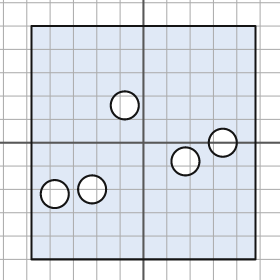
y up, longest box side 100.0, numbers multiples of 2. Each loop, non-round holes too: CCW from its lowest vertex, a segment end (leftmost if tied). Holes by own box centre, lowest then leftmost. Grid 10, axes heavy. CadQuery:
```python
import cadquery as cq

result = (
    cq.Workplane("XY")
    .moveTo(-48.0, -50.0)
    .lineTo(48.0, -50.0)
    .lineTo(48.0, 50.0)
    .lineTo(-48.0, 50.0)
    .close()
    .moveTo(-38.0, -22.0)
    .circle(6.0)
    .moveTo(-22.0, -20.0)
    .circle(6.0)
    .moveTo(18.0, -8.0)
    .circle(6.0)
    .moveTo(34.0, 0.0)
    .circle(6.0)
    .moveTo(-8.0, 16.0)
    .circle(6.0)
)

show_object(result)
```